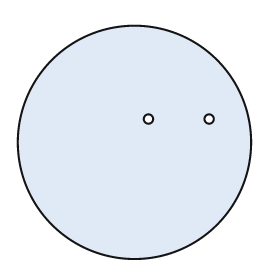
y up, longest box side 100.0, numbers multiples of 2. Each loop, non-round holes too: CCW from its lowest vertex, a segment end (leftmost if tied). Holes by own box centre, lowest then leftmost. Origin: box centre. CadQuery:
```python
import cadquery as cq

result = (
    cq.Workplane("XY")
    .moveTo(0.0, 0.0)
    .circle(50.0)
    .moveTo(6.0, 10.0)
    .circle(2.0)
    .moveTo(32.0, 10.0)
    .circle(2.0)
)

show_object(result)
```